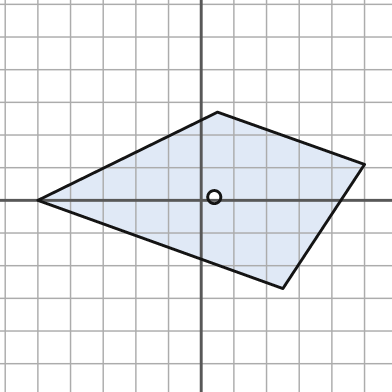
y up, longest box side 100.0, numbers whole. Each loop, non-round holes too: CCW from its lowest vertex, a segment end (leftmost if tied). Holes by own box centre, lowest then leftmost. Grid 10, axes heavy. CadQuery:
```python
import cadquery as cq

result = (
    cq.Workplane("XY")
    .moveTo(25.0, -27.0)
    .lineTo(50.0, 11.0)
    .lineTo(5.0, 27.0)
    .lineTo(-50.0, 0.0)
    .close()
    .moveTo(4.0, 1.0)
    .circle(2.0)
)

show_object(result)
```